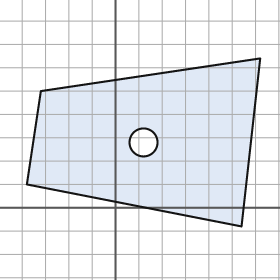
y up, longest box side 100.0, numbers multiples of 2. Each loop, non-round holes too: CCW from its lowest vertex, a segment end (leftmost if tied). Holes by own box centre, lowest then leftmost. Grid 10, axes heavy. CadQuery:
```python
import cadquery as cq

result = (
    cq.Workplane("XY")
    .moveTo(54.0, -8.0)
    .lineTo(62.0, 64.0)
    .lineTo(-32.0, 50.0)
    .lineTo(-38.0, 10.0)
    .close()
    .moveTo(12.0, 28.0)
    .circle(6.0)
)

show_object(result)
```